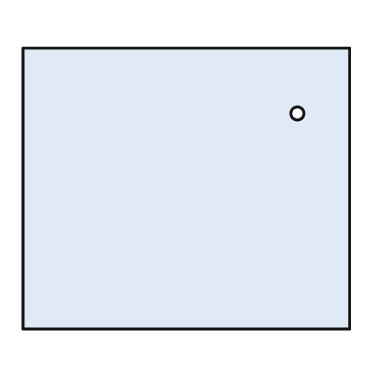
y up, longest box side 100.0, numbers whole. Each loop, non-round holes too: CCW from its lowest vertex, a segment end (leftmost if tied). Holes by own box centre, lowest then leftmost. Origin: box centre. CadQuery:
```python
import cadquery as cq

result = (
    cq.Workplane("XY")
    .moveTo(-50.0, -43.0)
    .lineTo(50.0, -43.0)
    .lineTo(50.0, 43.0)
    .lineTo(-50.0, 43.0)
    .close()
    .moveTo(34.0, 23.0)
    .circle(2.0)
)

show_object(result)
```